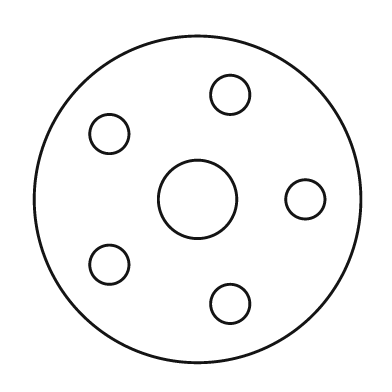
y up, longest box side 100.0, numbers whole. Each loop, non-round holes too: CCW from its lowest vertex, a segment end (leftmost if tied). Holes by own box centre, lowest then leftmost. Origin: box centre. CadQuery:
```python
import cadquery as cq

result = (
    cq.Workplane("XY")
    .moveTo(0.0, 0.0)
    .circle(50.0)
    .moveTo(10.0, -32.0)
    .circle(6.0)
    .moveTo(-27.0, -20.0)
    .circle(6.0)
    .moveTo(0.0, 0.0)
    .circle(12.0)
    .moveTo(33.0, 0.0)
    .circle(6.0)
    .moveTo(-27.0, 20.0)
    .circle(6.0)
    .moveTo(10.0, 32.0)
    .circle(6.0)
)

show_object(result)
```